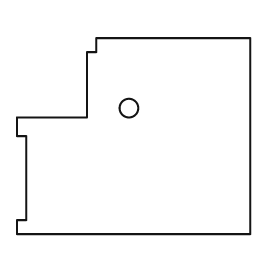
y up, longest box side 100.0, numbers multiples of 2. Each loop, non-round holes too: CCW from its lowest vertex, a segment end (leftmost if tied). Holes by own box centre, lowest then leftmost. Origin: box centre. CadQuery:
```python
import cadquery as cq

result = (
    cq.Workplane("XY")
    .moveTo(-50.0, -42.0)
    .lineTo(50.0, -42.0)
    .lineTo(50.0, 42.0)
    .lineTo(-16.0, 42.0)
    .lineTo(-16.0, 36.0)
    .lineTo(-20.0, 36.0)
    .lineTo(-20.0, 8.0)
    .lineTo(-50.0, 8.0)
    .lineTo(-50.0, 0.0)
    .lineTo(-46.0, 0.0)
    .lineTo(-46.0, -36.0)
    .lineTo(-50.0, -36.0)
    .close()
    .moveTo(-2.0, 12.0)
    .circle(4.0)
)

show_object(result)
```